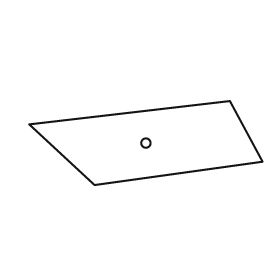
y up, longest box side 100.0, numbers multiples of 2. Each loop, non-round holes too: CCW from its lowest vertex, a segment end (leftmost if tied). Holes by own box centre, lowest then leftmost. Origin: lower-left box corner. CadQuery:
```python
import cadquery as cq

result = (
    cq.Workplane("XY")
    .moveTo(28.0, 0.0)
    .lineTo(100.0, 10.0)
    .lineTo(86.0, 36.0)
    .lineTo(0.0, 26.0)
    .close()
    .moveTo(50.0, 18.0)
    .circle(2.0)
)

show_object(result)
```